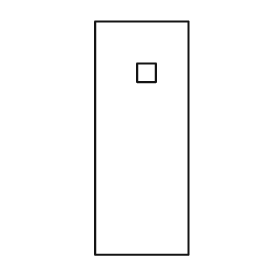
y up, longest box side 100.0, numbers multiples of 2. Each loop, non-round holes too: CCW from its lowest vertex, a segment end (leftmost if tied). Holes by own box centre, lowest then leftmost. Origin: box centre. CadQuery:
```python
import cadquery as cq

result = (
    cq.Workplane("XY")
    .moveTo(-20.0, -50.0)
    .lineTo(20.0, -50.0)
    .lineTo(20.0, 50.0)
    .lineTo(-20.0, 50.0)
    .close()
    .moveTo(-2.0, 24.0)
    .lineTo(6.0, 24.0)
    .lineTo(6.0, 32.0)
    .lineTo(-2.0, 32.0)
    .close()
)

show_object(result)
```